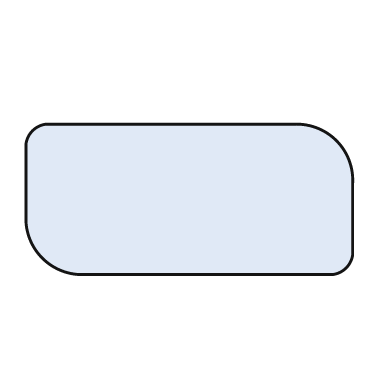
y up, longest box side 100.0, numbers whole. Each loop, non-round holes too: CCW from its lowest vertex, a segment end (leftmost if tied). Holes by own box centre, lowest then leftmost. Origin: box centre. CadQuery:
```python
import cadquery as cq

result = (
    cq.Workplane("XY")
    .moveTo(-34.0, -23.0)
    .lineTo(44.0, -23.0)
    .threePointArc((48.0, -21.0), (50.0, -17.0))
    .lineTo(50.0, 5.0)
    .threePointArc((45.0, 18.0), (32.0, 23.0))
    .lineTo(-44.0, 23.0)
    .threePointArc((-48.0, 21.0), (-50.0, 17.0))
    .lineTo(-50.0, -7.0)
    .threePointArc((-45.0, -18.0), (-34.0, -23.0))
    .close()
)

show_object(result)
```